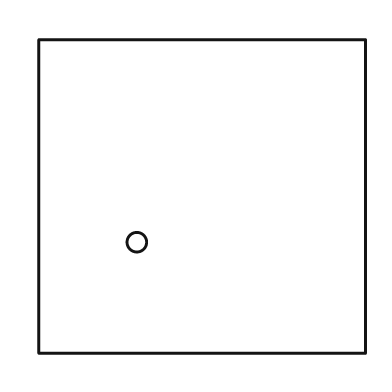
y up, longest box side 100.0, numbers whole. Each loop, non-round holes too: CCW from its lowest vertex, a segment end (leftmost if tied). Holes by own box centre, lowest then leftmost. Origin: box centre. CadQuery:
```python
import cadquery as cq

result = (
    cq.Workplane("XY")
    .moveTo(-50.0, -48.0)
    .lineTo(50.0, -48.0)
    .lineTo(50.0, 48.0)
    .lineTo(-50.0, 48.0)
    .close()
    .moveTo(-20.0, -14.0)
    .circle(3.0)
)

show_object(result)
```